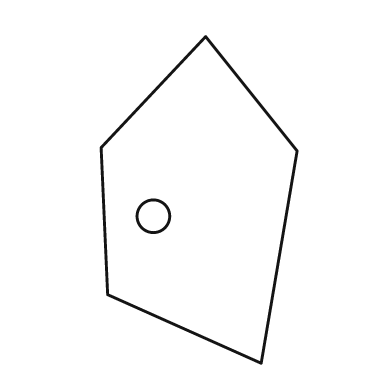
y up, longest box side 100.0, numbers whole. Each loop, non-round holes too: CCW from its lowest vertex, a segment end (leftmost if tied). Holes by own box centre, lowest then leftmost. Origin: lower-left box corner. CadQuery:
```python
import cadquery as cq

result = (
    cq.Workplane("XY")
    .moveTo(49.0, 0.0)
    .lineTo(60.0, 65.0)
    .lineTo(32.0, 100.0)
    .lineTo(0.0, 66.0)
    .lineTo(2.0, 21.0)
    .close()
    .moveTo(16.0, 45.0)
    .circle(5.0)
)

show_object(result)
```